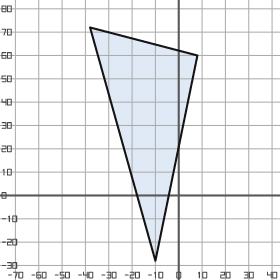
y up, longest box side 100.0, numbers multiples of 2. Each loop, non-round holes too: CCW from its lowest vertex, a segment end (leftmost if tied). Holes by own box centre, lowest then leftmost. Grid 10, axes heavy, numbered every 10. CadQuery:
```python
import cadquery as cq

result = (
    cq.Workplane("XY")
    .moveTo(-10.0, -28.0)
    .lineTo(8.0, 60.0)
    .lineTo(-38.0, 72.0)
    .close()
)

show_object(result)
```